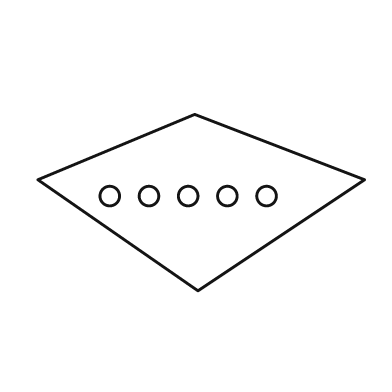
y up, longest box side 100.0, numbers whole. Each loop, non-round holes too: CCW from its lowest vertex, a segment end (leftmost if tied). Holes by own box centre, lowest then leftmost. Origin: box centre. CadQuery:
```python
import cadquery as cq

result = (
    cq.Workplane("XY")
    .moveTo(-1.0, -27.0)
    .lineTo(50.0, 7.0)
    .lineTo(-2.0, 27.0)
    .lineTo(-50.0, 7.0)
    .close()
    .moveTo(-28.0, 2.0)
    .circle(3.0)
    .moveTo(-16.0, 2.0)
    .circle(3.0)
    .moveTo(-4.0, 2.0)
    .circle(3.0)
    .moveTo(8.0, 2.0)
    .circle(3.0)
    .moveTo(20.0, 2.0)
    .circle(3.0)
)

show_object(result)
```